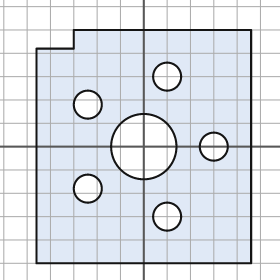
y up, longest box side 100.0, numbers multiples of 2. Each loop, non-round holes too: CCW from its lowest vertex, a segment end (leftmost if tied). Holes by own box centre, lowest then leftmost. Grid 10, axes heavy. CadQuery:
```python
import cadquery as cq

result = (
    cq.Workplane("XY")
    .moveTo(-46.0, -50.0)
    .lineTo(46.0, -50.0)
    .lineTo(46.0, 50.0)
    .lineTo(-30.0, 50.0)
    .lineTo(-30.0, 42.0)
    .lineTo(-46.0, 42.0)
    .close()
    .moveTo(10.0, -30.0)
    .circle(6.0)
    .moveTo(-24.0, -18.0)
    .circle(6.0)
    .moveTo(0.0, 0.0)
    .circle(14.0)
    .moveTo(30.0, 0.0)
    .circle(6.0)
    .moveTo(-24.0, 18.0)
    .circle(6.0)
    .moveTo(10.0, 30.0)
    .circle(6.0)
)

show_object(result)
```